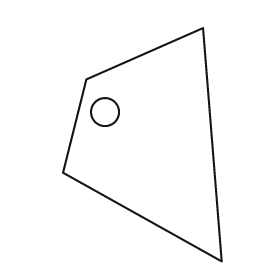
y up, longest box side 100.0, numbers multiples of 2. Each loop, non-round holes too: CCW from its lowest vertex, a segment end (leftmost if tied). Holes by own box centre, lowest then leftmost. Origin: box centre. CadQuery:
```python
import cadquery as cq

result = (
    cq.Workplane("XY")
    .moveTo(34.0, -50.0)
    .lineTo(26.0, 50.0)
    .lineTo(-24.0, 28.0)
    .lineTo(-34.0, -12.0)
    .close()
    .moveTo(-16.0, 14.0)
    .circle(6.0)
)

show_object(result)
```